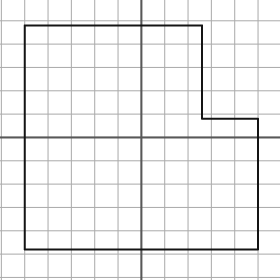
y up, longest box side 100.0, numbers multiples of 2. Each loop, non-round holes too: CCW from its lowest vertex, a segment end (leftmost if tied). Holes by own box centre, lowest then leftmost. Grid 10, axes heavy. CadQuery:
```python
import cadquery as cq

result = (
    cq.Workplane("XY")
    .moveTo(-50.0, -48.0)
    .lineTo(50.0, -48.0)
    .lineTo(50.0, 8.0)
    .lineTo(26.0, 8.0)
    .lineTo(26.0, 48.0)
    .lineTo(-50.0, 48.0)
    .close()
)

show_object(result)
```